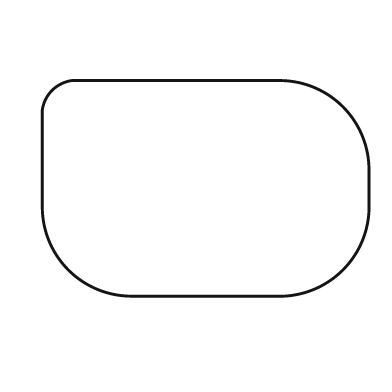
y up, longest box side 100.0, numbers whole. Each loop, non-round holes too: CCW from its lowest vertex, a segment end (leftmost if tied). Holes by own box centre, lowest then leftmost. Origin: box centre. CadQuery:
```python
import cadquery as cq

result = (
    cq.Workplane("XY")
    .moveTo(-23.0, -33.0)
    .lineTo(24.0, -33.0)
    .threePointArc((42.0, -25.0), (50.0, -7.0))
    .lineTo(50.0, 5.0)
    .threePointArc((42.0, 25.0), (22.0, 33.0))
    .lineTo(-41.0, 33.0)
    .threePointArc((-47.0, 30.0), (-50.0, 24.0))
    .lineTo(-50.0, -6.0)
    .threePointArc((-42.0, -25.0), (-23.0, -33.0))
    .close()
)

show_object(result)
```